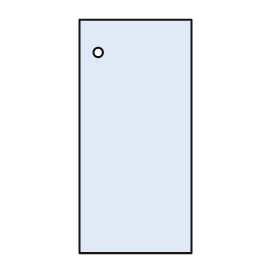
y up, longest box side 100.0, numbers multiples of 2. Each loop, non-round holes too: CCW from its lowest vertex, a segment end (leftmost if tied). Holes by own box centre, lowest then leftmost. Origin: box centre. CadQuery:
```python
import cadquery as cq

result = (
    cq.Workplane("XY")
    .moveTo(-24.0, -50.0)
    .lineTo(24.0, -50.0)
    .lineTo(24.0, 50.0)
    .lineTo(-24.0, 50.0)
    .close()
    .moveTo(-16.0, 36.0)
    .circle(2.0)
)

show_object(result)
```